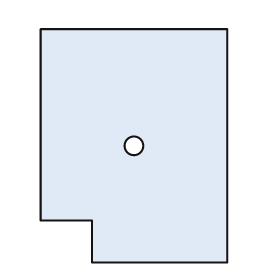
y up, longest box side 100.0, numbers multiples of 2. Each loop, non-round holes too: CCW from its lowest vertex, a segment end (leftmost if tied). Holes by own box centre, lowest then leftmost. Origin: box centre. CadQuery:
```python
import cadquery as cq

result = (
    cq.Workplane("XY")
    .moveTo(-18.0, -50.0)
    .lineTo(40.0, -50.0)
    .lineTo(40.0, 50.0)
    .lineTo(-40.0, 50.0)
    .lineTo(-40.0, -32.0)
    .lineTo(-18.0, -32.0)
    .close()
    .moveTo(0.0, 0.0)
    .circle(4.0)
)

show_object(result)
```